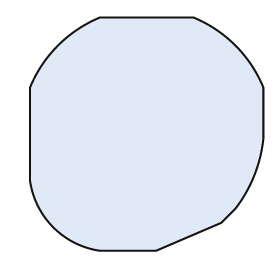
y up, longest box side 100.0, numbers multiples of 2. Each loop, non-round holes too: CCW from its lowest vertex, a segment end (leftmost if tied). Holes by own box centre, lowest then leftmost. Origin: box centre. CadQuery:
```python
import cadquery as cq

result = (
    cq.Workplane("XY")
    .moveTo(-20.0, -50.0)
    .lineTo(4.0, -50.0)
    .lineTo(32.0, -38.0)
    .lineTo(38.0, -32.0)
    .threePointArc((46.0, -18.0), (50.0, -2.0))
    .lineTo(50.0, 20.0)
    .threePointArc((38.0, 38.0), (20.0, 50.0))
    .lineTo(-20.0, 50.0)
    .threePointArc((-38.0, 38.0), (-50.0, 20.0))
    .lineTo(-50.0, -20.0)
    .threePointArc((-40.0, -40.0), (-20.0, -50.0))
    .close()
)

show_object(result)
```